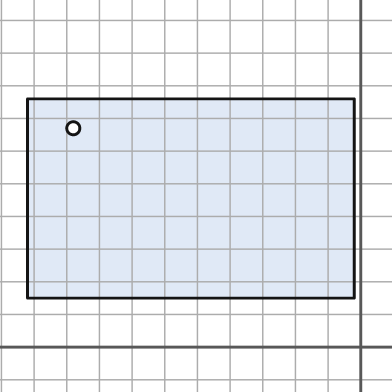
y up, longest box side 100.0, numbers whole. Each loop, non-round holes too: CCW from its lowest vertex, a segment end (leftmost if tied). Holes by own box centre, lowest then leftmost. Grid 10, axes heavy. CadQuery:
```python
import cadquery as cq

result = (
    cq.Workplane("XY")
    .moveTo(-102.0, 15.0)
    .lineTo(-2.0, 15.0)
    .lineTo(-2.0, 76.0)
    .lineTo(-102.0, 76.0)
    .close()
    .moveTo(-88.0, 67.0)
    .circle(2.0)
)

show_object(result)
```